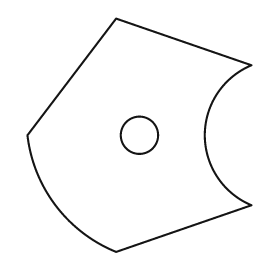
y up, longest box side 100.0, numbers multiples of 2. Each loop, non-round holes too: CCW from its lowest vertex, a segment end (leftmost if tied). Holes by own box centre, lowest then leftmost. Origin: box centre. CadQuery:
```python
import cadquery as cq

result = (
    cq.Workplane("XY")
    .moveTo(-10.0, -50.0)
    .lineTo(48.0, -30.0)
    .threePointArc((28.0, 0.0), (48.0, 30.0))
    .lineTo(-10.0, 50.0)
    .lineTo(-48.0, 0.0)
    .threePointArc((-36.0, -30.0), (-10.0, -50.0))
    .close()
    .moveTo(0.0, 0.0)
    .circle(8.0)
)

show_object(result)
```